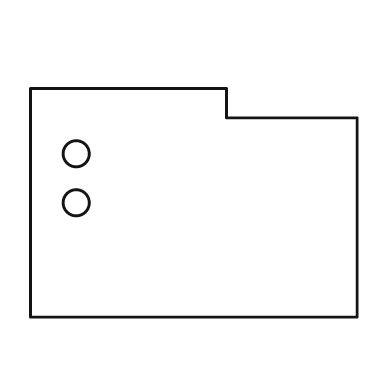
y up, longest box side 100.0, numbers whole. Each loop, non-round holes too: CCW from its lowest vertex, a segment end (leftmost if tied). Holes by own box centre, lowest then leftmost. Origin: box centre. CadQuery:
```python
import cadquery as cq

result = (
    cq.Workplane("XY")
    .moveTo(-50.0, -35.0)
    .lineTo(50.0, -35.0)
    .lineTo(50.0, 26.0)
    .lineTo(10.0, 26.0)
    .lineTo(10.0, 35.0)
    .lineTo(-50.0, 35.0)
    .close()
    .moveTo(-36.0, 0.0)
    .circle(4.0)
    .moveTo(-36.0, 15.0)
    .circle(4.0)
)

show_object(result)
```